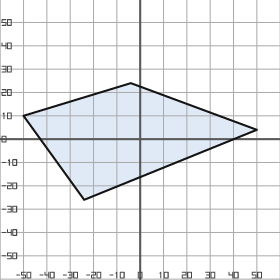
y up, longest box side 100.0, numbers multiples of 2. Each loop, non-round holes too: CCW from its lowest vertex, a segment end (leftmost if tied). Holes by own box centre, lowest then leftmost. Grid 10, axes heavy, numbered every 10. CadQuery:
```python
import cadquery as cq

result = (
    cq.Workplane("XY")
    .moveTo(-24.0, -26.0)
    .lineTo(50.0, 4.0)
    .lineTo(-4.0, 24.0)
    .lineTo(-50.0, 10.0)
    .close()
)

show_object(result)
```